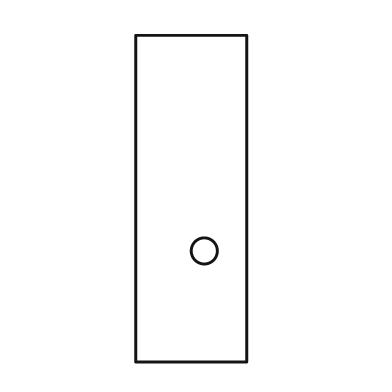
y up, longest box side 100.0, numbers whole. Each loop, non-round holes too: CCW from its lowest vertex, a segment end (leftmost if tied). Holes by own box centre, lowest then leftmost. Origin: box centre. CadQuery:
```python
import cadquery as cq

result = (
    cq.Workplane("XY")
    .moveTo(-17.0, -50.0)
    .lineTo(17.0, -50.0)
    .lineTo(17.0, 50.0)
    .lineTo(-17.0, 50.0)
    .close()
    .moveTo(4.0, -16.0)
    .circle(4.0)
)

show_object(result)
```